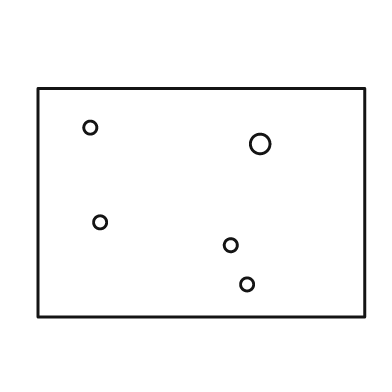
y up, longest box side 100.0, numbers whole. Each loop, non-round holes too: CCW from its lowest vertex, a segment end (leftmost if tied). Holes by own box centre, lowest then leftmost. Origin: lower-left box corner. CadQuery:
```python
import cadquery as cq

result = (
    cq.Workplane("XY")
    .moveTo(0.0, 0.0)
    .lineTo(100.0, 0.0)
    .lineTo(100.0, 70.0)
    .lineTo(0.0, 70.0)
    .close()
    .moveTo(64.0, 10.0)
    .circle(2.0)
    .moveTo(59.0, 22.0)
    .circle(2.0)
    .moveTo(19.0, 29.0)
    .circle(2.0)
    .moveTo(68.0, 53.0)
    .circle(3.0)
    .moveTo(16.0, 58.0)
    .circle(2.0)
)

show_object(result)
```